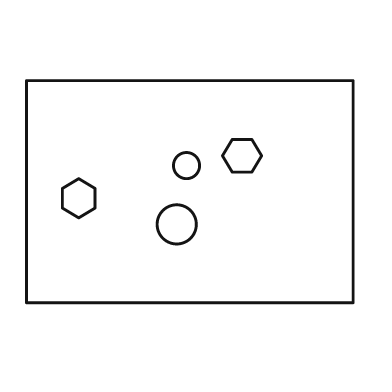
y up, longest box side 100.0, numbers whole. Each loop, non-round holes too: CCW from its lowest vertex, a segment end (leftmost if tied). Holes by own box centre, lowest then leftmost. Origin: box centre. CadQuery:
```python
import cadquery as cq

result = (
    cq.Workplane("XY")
    .moveTo(-50.0, -34.0)
    .lineTo(50.0, -34.0)
    .lineTo(50.0, 34.0)
    .lineTo(-50.0, 34.0)
    .close()
    .moveTo(-4.0, -10.0)
    .circle(6.0)
    .moveTo(-34.0, -8.0)
    .lineTo(-29.0, -5.0)
    .lineTo(-29.0, 1.0)
    .lineTo(-34.0, 4.0)
    .lineTo(-39.0, 1.0)
    .lineTo(-39.0, -5.0)
    .close()
    .moveTo(-1.0, 8.0)
    .circle(4.0)
    .moveTo(13.0, 6.0)
    .lineTo(19.0, 6.0)
    .lineTo(22.0, 11.0)
    .lineTo(19.0, 16.0)
    .lineTo(13.0, 16.0)
    .lineTo(10.0, 11.0)
    .close()
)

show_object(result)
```